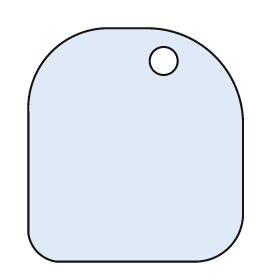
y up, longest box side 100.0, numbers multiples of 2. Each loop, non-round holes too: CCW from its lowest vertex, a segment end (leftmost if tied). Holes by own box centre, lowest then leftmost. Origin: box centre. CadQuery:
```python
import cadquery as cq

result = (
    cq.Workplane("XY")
    .moveTo(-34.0, -50.0)
    .lineTo(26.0, -50.0)
    .threePointArc((40.0, -44.0), (46.0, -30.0))
    .lineTo(46.0, 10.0)
    .threePointArc((34.0, 38.0), (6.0, 50.0))
    .lineTo(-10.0, 50.0)
    .threePointArc((-36.0, 40.0), (-46.0, 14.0))
    .lineTo(-46.0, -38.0)
    .threePointArc((-42.0, -46.0), (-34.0, -50.0))
    .close()
    .moveTo(12.0, 36.0)
    .circle(6.0)
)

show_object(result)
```